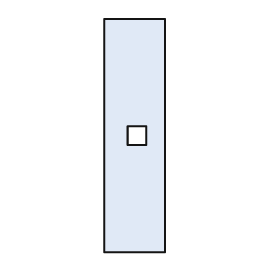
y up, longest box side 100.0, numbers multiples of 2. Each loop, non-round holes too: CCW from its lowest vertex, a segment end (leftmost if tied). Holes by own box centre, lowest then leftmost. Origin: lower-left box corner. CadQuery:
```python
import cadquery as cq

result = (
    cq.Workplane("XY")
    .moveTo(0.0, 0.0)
    .lineTo(26.0, 0.0)
    .lineTo(26.0, 100.0)
    .lineTo(0.0, 100.0)
    .close()
    .moveTo(10.0, 46.0)
    .lineTo(18.0, 46.0)
    .lineTo(18.0, 54.0)
    .lineTo(10.0, 54.0)
    .close()
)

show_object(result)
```